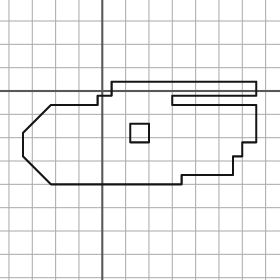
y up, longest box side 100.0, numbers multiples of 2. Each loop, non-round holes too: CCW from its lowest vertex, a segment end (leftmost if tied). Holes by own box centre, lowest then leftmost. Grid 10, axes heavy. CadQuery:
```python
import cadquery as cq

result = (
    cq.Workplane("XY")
    .moveTo(-22.0, -40.0)
    .lineTo(34.0, -40.0)
    .lineTo(34.0, -36.0)
    .lineTo(56.0, -36.0)
    .lineTo(56.0, -28.0)
    .lineTo(60.0, -28.0)
    .lineTo(60.0, -22.0)
    .lineTo(66.0, -22.0)
    .lineTo(66.0, -6.0)
    .lineTo(30.0, -6.0)
    .lineTo(30.0, -2.0)
    .lineTo(66.0, -2.0)
    .lineTo(66.0, 4.0)
    .lineTo(4.0, 4.0)
    .lineTo(4.0, -2.0)
    .lineTo(-2.0, -2.0)
    .lineTo(-2.0, -6.0)
    .lineTo(-22.0, -6.0)
    .lineTo(-34.0, -18.0)
    .lineTo(-34.0, -28.0)
    .close()
    .moveTo(12.0, -22.0)
    .lineTo(20.0, -22.0)
    .lineTo(20.0, -14.0)
    .lineTo(12.0, -14.0)
    .close()
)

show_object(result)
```